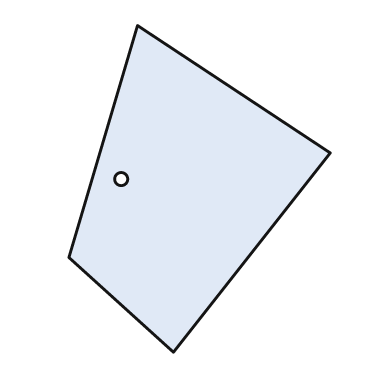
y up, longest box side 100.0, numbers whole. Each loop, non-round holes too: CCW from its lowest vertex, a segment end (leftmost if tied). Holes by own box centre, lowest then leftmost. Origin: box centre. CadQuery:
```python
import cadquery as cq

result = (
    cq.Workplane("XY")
    .moveTo(-8.0, -50.0)
    .lineTo(40.0, 11.0)
    .lineTo(-19.0, 50.0)
    .lineTo(-40.0, -21.0)
    .close()
    .moveTo(-24.0, 3.0)
    .circle(2.0)
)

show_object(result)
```